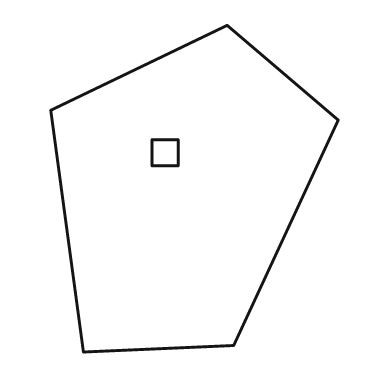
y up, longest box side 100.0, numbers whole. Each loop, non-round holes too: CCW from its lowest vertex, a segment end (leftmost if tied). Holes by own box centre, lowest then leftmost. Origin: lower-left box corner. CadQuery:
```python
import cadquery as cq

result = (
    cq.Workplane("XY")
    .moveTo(10.0, 0.0)
    .lineTo(56.0, 2.0)
    .lineTo(88.0, 71.0)
    .lineTo(54.0, 100.0)
    .lineTo(0.0, 74.0)
    .close()
    .moveTo(31.0, 57.0)
    .lineTo(39.0, 57.0)
    .lineTo(39.0, 65.0)
    .lineTo(31.0, 65.0)
    .close()
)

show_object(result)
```